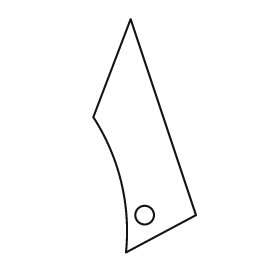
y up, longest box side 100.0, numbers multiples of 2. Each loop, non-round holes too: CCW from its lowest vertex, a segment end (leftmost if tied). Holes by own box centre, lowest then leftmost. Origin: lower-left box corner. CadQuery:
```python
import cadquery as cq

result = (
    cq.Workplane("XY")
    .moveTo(14.0, 0.0)
    .lineTo(44.0, 16.0)
    .lineTo(16.0, 100.0)
    .lineTo(0.0, 58.0)
    .threePointArc((12.0, 30.0), (14.0, 0.0))
    .close()
    .moveTo(22.0, 16.0)
    .circle(4.0)
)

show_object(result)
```